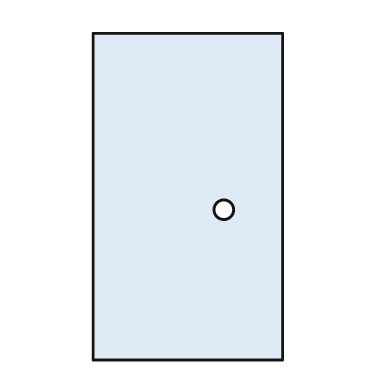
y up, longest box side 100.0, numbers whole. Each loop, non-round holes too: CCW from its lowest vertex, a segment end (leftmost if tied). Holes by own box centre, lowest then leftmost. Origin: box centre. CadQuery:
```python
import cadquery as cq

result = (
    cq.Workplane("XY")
    .moveTo(-29.0, -50.0)
    .lineTo(29.0, -50.0)
    .lineTo(29.0, 50.0)
    .lineTo(-29.0, 50.0)
    .close()
    .moveTo(11.0, -4.0)
    .circle(3.0)
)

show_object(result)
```